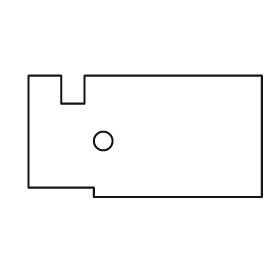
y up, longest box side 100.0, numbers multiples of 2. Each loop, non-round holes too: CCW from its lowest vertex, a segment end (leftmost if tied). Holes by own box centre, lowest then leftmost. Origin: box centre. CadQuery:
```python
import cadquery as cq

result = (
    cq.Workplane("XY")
    .moveTo(-22.0, -26.0)
    .lineTo(50.0, -26.0)
    .lineTo(50.0, 26.0)
    .lineTo(-26.0, 26.0)
    .lineTo(-26.0, 14.0)
    .lineTo(-36.0, 14.0)
    .lineTo(-36.0, 26.0)
    .lineTo(-50.0, 26.0)
    .lineTo(-50.0, -22.0)
    .lineTo(-22.0, -22.0)
    .close()
    .moveTo(-18.0, -2.0)
    .circle(4.0)
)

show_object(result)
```